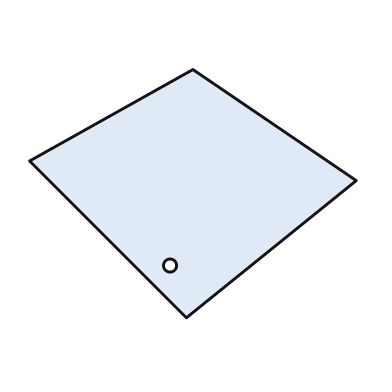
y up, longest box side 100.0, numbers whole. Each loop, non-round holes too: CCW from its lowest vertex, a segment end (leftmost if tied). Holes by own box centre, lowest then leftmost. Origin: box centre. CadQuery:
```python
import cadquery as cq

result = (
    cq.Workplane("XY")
    .moveTo(-2.0, -38.0)
    .lineTo(50.0, 4.0)
    .lineTo(0.0, 38.0)
    .lineTo(-50.0, 10.0)
    .close()
    .moveTo(-7.0, -22.0)
    .circle(2.0)
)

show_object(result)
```